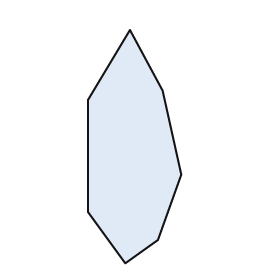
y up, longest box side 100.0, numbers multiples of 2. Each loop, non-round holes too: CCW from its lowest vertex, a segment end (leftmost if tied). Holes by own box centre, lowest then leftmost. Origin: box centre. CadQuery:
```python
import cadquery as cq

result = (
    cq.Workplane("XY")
    .moveTo(-4.0, -50.0)
    .lineTo(10.0, -40.0)
    .lineTo(20.0, -12.0)
    .lineTo(12.0, 24.0)
    .lineTo(-2.0, 50.0)
    .lineTo(-20.0, 20.0)
    .lineTo(-20.0, -28.0)
    .close()
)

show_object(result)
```